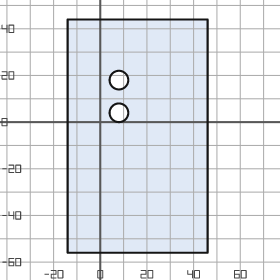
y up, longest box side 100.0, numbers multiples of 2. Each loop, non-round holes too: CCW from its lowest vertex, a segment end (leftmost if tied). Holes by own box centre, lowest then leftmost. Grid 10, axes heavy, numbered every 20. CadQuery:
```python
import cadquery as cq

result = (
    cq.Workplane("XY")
    .moveTo(-14.0, -56.0)
    .lineTo(46.0, -56.0)
    .lineTo(46.0, 44.0)
    .lineTo(-14.0, 44.0)
    .close()
    .moveTo(8.0, 4.0)
    .circle(4.0)
    .moveTo(8.0, 18.0)
    .circle(4.0)
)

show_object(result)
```